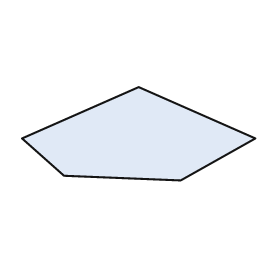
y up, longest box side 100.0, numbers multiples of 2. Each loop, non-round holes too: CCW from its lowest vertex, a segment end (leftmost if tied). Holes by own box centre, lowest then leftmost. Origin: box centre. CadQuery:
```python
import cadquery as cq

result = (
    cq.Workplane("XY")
    .moveTo(18.0, -20.0)
    .lineTo(50.0, -2.0)
    .lineTo(0.0, 20.0)
    .lineTo(-50.0, -2.0)
    .lineTo(-32.0, -18.0)
    .close()
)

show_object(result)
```